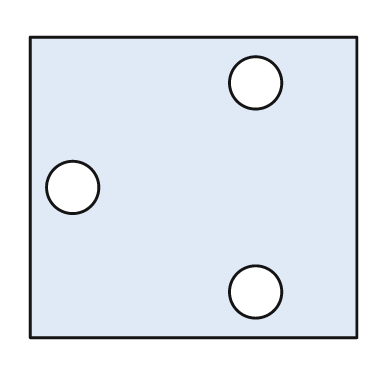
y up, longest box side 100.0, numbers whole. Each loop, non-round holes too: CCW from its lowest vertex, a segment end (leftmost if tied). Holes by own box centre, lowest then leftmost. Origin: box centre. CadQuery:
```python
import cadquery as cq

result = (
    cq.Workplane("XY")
    .moveTo(-50.0, -46.0)
    .lineTo(50.0, -46.0)
    .lineTo(50.0, 46.0)
    .lineTo(-50.0, 46.0)
    .close()
    .moveTo(19.0, -32.0)
    .circle(8.0)
    .moveTo(-37.0, 0.0)
    .circle(8.0)
    .moveTo(19.0, 32.0)
    .circle(8.0)
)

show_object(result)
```